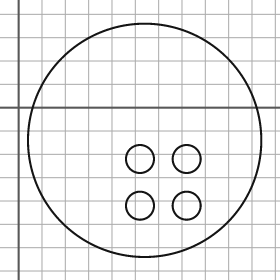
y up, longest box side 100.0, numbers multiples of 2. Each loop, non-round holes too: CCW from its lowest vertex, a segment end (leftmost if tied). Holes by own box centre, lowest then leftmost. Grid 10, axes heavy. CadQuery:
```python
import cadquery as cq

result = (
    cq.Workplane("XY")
    .moveTo(54.0, -14.0)
    .circle(50.0)
    .moveTo(52.0, -42.0)
    .circle(6.0)
    .moveTo(72.0, -42.0)
    .circle(6.0)
    .moveTo(52.0, -22.0)
    .circle(6.0)
    .moveTo(72.0, -22.0)
    .circle(6.0)
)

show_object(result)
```